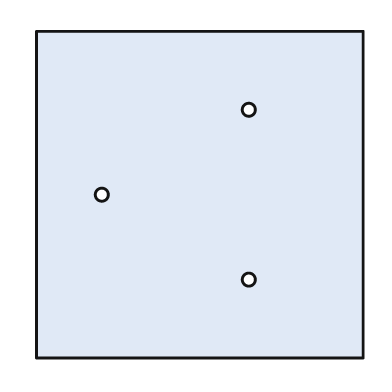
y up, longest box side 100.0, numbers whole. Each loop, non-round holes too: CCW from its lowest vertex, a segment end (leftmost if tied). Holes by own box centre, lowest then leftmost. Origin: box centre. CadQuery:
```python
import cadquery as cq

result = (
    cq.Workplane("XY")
    .moveTo(-50.0, -50.0)
    .lineTo(50.0, -50.0)
    .lineTo(50.0, 50.0)
    .lineTo(-50.0, 50.0)
    .close()
    .moveTo(15.0, -26.0)
    .circle(2.0)
    .moveTo(-30.0, 0.0)
    .circle(2.0)
    .moveTo(15.0, 26.0)
    .circle(2.0)
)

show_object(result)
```